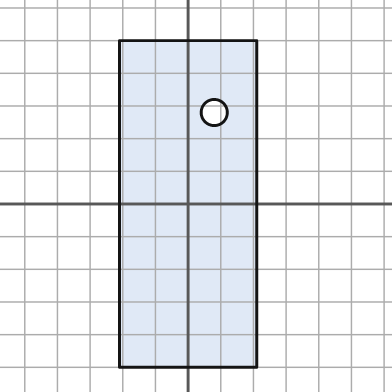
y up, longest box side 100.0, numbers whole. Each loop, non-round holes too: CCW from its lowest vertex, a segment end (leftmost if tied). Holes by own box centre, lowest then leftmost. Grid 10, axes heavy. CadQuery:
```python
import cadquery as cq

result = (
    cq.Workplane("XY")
    .moveTo(-21.0, -50.0)
    .lineTo(21.0, -50.0)
    .lineTo(21.0, 50.0)
    .lineTo(-21.0, 50.0)
    .close()
    .moveTo(8.0, 28.0)
    .circle(4.0)
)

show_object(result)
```